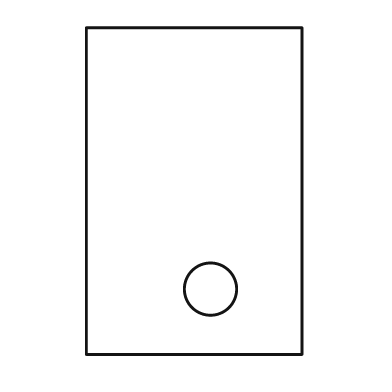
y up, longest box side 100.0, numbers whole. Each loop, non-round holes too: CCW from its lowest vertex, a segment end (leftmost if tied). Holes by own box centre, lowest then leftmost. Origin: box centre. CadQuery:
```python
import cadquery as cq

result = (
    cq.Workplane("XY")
    .moveTo(-33.0, -50.0)
    .lineTo(33.0, -50.0)
    .lineTo(33.0, 50.0)
    .lineTo(-33.0, 50.0)
    .close()
    .moveTo(5.0, -30.0)
    .circle(8.0)
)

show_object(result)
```